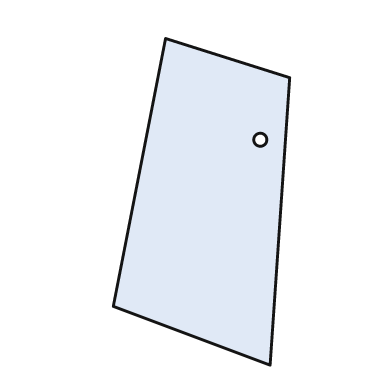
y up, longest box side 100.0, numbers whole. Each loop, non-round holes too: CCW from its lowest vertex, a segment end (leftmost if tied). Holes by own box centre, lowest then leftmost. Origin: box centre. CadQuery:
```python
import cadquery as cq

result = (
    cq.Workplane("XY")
    .moveTo(21.0, -50.0)
    .lineTo(27.0, 38.0)
    .lineTo(-11.0, 50.0)
    .lineTo(-27.0, -32.0)
    .close()
    .moveTo(18.0, 19.0)
    .circle(2.0)
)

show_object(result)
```